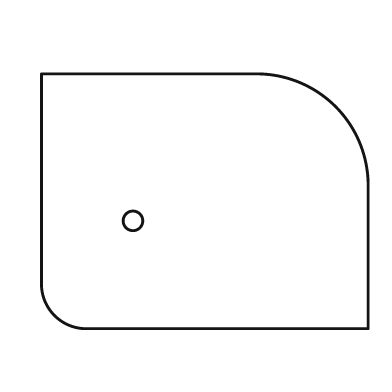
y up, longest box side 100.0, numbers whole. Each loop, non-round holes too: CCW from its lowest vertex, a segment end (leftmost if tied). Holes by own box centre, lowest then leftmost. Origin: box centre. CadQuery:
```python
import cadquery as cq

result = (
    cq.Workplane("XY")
    .moveTo(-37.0, -39.0)
    .lineTo(50.0, -39.0)
    .lineTo(50.0, 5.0)
    .threePointArc((40.0, 29.0), (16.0, 39.0))
    .lineTo(-50.0, 39.0)
    .lineTo(-50.0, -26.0)
    .threePointArc((-46.0, -35.0), (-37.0, -39.0))
    .close()
    .moveTo(-22.0, -6.0)
    .circle(3.0)
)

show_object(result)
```